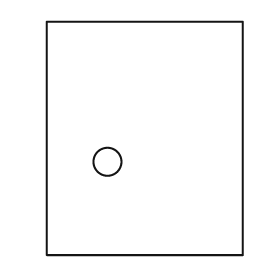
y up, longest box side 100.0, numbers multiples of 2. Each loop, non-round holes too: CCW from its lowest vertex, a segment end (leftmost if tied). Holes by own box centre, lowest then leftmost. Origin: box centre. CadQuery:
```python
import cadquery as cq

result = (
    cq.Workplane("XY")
    .moveTo(-42.0, -50.0)
    .lineTo(42.0, -50.0)
    .lineTo(42.0, 50.0)
    .lineTo(-42.0, 50.0)
    .close()
    .moveTo(-16.0, -10.0)
    .circle(6.0)
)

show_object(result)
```